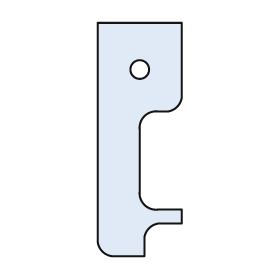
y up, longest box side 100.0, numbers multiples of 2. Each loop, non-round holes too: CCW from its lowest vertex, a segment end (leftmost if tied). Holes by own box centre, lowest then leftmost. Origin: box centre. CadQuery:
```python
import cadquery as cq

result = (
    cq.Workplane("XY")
    .moveTo(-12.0, -50.0)
    .lineTo(2.0, -50.0)
    .lineTo(2.0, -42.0)
    .threePointArc((4.0, -38.0), (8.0, -36.0))
    .lineTo(18.0, -36.0)
    .lineTo(18.0, -30.0)
    .lineTo(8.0, -30.0)
    .threePointArc((2.0, -28.0), (0.0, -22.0))
    .lineTo(0.0, 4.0)
    .threePointArc((2.0, 10.0), (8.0, 12.0))
    .lineTo(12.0, 12.0)
    .threePointArc((16.0, 14.0), (18.0, 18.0))
    .lineTo(18.0, 50.0)
    .lineTo(-18.0, 50.0)
    .lineTo(-18.0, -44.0)
    .threePointArc((-16.0, -48.0), (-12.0, -50.0))
    .close()
    .moveTo(0.0, 30.0)
    .circle(4.0)
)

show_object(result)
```